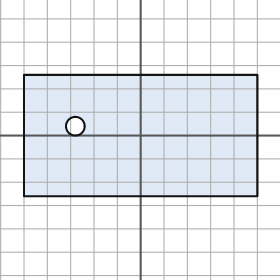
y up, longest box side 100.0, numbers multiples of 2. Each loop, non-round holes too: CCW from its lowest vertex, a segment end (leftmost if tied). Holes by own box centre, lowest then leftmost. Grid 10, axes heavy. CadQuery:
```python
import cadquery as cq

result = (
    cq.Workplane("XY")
    .moveTo(-50.0, -26.0)
    .lineTo(50.0, -26.0)
    .lineTo(50.0, 26.0)
    .lineTo(-50.0, 26.0)
    .close()
    .moveTo(-28.0, 4.0)
    .circle(4.0)
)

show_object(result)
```